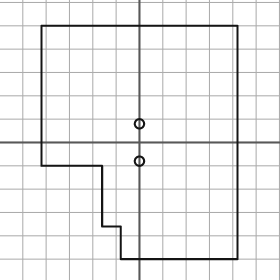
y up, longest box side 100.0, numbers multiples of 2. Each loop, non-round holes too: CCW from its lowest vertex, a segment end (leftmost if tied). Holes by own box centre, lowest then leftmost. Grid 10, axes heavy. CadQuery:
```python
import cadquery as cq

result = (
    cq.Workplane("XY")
    .moveTo(-8.0, -50.0)
    .lineTo(42.0, -50.0)
    .lineTo(42.0, 50.0)
    .lineTo(-42.0, 50.0)
    .lineTo(-42.0, -10.0)
    .lineTo(-16.0, -10.0)
    .lineTo(-16.0, -36.0)
    .lineTo(-8.0, -36.0)
    .close()
    .moveTo(0.0, -8.0)
    .circle(2.0)
    .moveTo(0.0, 8.0)
    .circle(2.0)
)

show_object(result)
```